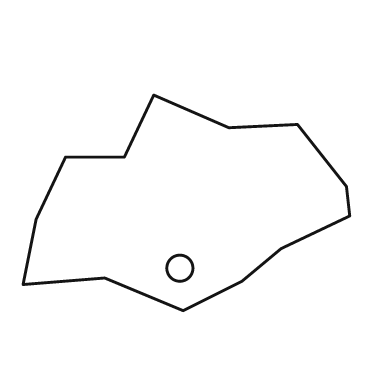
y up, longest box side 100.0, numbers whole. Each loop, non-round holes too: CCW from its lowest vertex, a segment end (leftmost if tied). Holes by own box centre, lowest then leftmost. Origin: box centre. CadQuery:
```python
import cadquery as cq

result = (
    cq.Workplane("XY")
    .moveTo(-1.0, -33.0)
    .lineTo(17.0, -24.0)
    .lineTo(29.0, -14.0)
    .lineTo(50.0, -4.0)
    .lineTo(49.0, 5.0)
    .lineTo(34.0, 24.0)
    .lineTo(13.0, 23.0)
    .lineTo(-10.0, 33.0)
    .lineTo(-19.0, 14.0)
    .lineTo(-37.0, 14.0)
    .lineTo(-46.0, -5.0)
    .lineTo(-50.0, -25.0)
    .lineTo(-25.0, -23.0)
    .close()
    .moveTo(-2.0, -20.0)
    .circle(4.0)
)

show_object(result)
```